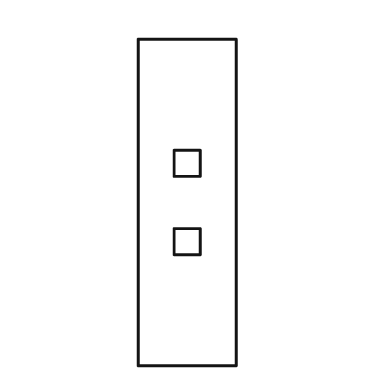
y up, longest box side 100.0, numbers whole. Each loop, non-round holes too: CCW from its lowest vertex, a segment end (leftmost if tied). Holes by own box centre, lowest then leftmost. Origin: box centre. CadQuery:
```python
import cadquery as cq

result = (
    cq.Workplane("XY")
    .moveTo(-15.0, -50.0)
    .lineTo(15.0, -50.0)
    .lineTo(15.0, 50.0)
    .lineTo(-15.0, 50.0)
    .close()
    .moveTo(-4.0, -16.0)
    .lineTo(4.0, -16.0)
    .lineTo(4.0, -8.0)
    .lineTo(-4.0, -8.0)
    .close()
    .moveTo(-4.0, 8.0)
    .lineTo(4.0, 8.0)
    .lineTo(4.0, 16.0)
    .lineTo(-4.0, 16.0)
    .close()
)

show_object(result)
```